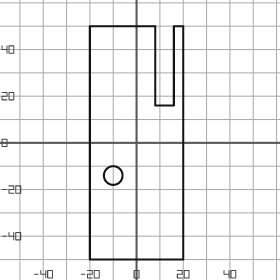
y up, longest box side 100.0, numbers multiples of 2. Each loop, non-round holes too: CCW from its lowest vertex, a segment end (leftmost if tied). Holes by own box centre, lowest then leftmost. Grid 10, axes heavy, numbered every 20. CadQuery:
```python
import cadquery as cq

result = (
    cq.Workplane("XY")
    .moveTo(-20.0, -50.0)
    .lineTo(20.0, -50.0)
    .lineTo(20.0, 50.0)
    .lineTo(16.0, 50.0)
    .lineTo(16.0, 16.0)
    .lineTo(8.0, 16.0)
    .lineTo(8.0, 50.0)
    .lineTo(-20.0, 50.0)
    .close()
    .moveTo(-10.0, -14.0)
    .circle(4.0)
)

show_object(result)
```